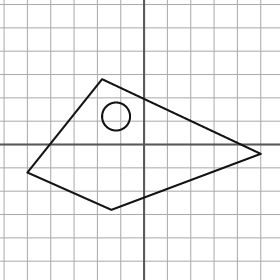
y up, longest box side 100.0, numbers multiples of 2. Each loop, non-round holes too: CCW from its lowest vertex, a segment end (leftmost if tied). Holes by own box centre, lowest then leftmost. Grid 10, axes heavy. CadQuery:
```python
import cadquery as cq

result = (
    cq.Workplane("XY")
    .moveTo(-14.0, -28.0)
    .lineTo(50.0, -4.0)
    .lineTo(-18.0, 28.0)
    .lineTo(-50.0, -12.0)
    .close()
    .moveTo(-12.0, 12.0)
    .circle(6.0)
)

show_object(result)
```